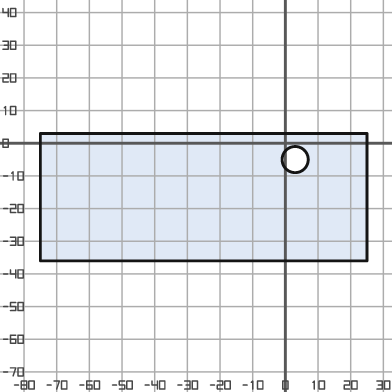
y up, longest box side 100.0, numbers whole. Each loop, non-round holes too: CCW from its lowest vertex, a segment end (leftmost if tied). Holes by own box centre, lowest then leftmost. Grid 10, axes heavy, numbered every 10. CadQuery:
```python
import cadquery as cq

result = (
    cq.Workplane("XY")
    .moveTo(-75.0, -36.0)
    .lineTo(25.0, -36.0)
    .lineTo(25.0, 3.0)
    .lineTo(-75.0, 3.0)
    .close()
    .moveTo(3.0, -5.0)
    .circle(4.0)
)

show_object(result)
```